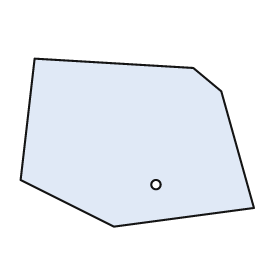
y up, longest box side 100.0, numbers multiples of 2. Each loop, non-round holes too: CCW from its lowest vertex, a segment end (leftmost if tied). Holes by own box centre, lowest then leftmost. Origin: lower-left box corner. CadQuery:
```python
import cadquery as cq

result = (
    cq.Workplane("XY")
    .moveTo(40.0, 0.0)
    .lineTo(100.0, 8.0)
    .lineTo(86.0, 58.0)
    .lineTo(74.0, 68.0)
    .lineTo(6.0, 72.0)
    .lineTo(0.0, 20.0)
    .close()
    .moveTo(58.0, 18.0)
    .circle(2.0)
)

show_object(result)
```